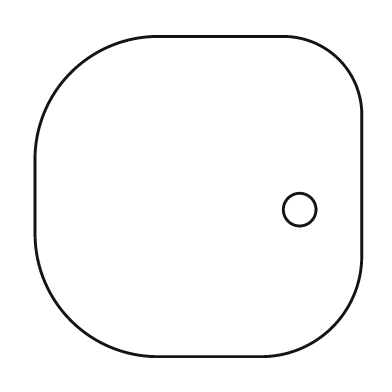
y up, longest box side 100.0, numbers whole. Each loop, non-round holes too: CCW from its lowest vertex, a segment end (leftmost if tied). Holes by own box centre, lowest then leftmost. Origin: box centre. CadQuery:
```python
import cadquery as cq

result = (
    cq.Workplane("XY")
    .moveTo(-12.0, -49.0)
    .lineTo(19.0, -49.0)
    .threePointArc((41.0, -40.0), (50.0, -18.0))
    .lineTo(50.0, 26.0)
    .threePointArc((43.0, 42.0), (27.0, 49.0))
    .lineTo(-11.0, 49.0)
    .threePointArc((-39.0, 38.0), (-50.0, 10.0))
    .lineTo(-50.0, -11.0)
    .threePointArc((-39.0, -38.0), (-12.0, -49.0))
    .close()
    .moveTo(31.0, -4.0)
    .circle(5.0)
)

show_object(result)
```